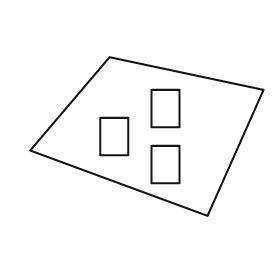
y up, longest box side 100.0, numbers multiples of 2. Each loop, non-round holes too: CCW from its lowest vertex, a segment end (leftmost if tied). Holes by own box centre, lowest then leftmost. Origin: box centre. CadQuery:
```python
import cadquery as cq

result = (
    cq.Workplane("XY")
    .moveTo(26.0, -34.0)
    .lineTo(50.0, 20.0)
    .lineTo(-16.0, 34.0)
    .lineTo(-50.0, -6.0)
    .close()
    .moveTo(2.0, -20.0)
    .lineTo(14.0, -20.0)
    .lineTo(14.0, -4.0)
    .lineTo(2.0, -4.0)
    .close()
    .moveTo(-20.0, -8.0)
    .lineTo(-8.0, -8.0)
    .lineTo(-8.0, 8.0)
    .lineTo(-20.0, 8.0)
    .close()
    .moveTo(2.0, 4.0)
    .lineTo(14.0, 4.0)
    .lineTo(14.0, 20.0)
    .lineTo(2.0, 20.0)
    .close()
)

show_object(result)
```